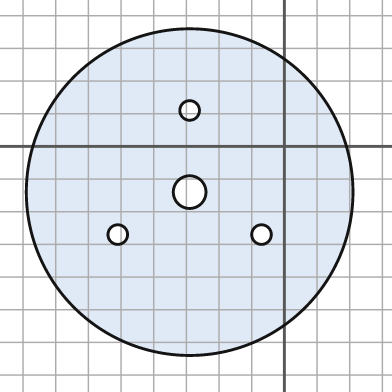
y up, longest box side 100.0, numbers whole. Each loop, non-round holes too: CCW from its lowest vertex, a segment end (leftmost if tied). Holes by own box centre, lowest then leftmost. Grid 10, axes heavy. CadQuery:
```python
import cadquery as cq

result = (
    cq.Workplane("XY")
    .moveTo(-29.0, -14.0)
    .circle(50.0)
    .moveTo(-51.0, -27.0)
    .circle(3.0)
    .moveTo(-7.0, -27.0)
    .circle(3.0)
    .moveTo(-29.0, -14.0)
    .circle(5.0)
    .moveTo(-29.0, 11.0)
    .circle(3.0)
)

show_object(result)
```